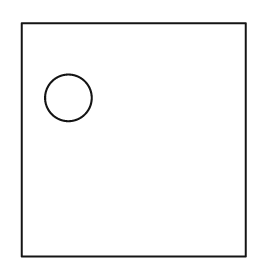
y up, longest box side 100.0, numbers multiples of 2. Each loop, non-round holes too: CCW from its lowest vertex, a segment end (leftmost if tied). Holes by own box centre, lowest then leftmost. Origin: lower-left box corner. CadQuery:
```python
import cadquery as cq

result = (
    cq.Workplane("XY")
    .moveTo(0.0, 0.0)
    .lineTo(96.0, 0.0)
    .lineTo(96.0, 100.0)
    .lineTo(0.0, 100.0)
    .close()
    .moveTo(20.0, 68.0)
    .circle(10.0)
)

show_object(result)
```